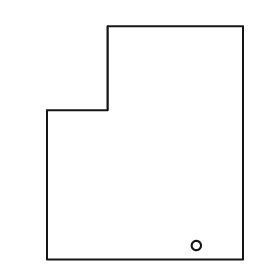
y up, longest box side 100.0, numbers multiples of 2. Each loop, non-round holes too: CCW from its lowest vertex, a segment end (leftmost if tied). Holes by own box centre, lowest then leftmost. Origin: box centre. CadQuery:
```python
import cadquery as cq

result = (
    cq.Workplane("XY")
    .moveTo(-42.0, -50.0)
    .lineTo(42.0, -50.0)
    .lineTo(42.0, 50.0)
    .lineTo(-16.0, 50.0)
    .lineTo(-16.0, 14.0)
    .lineTo(-42.0, 14.0)
    .close()
    .moveTo(22.0, -44.0)
    .circle(2.0)
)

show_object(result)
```